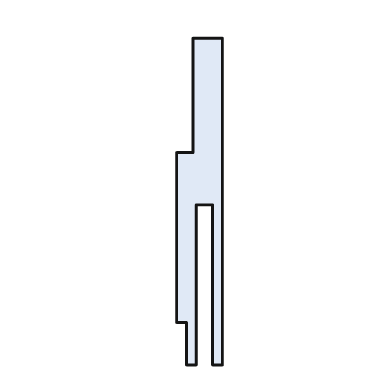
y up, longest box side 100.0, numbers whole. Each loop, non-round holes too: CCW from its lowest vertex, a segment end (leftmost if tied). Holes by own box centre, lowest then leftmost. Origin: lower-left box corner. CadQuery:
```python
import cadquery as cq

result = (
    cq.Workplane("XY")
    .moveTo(3.0, 0.0)
    .lineTo(6.0, 0.0)
    .lineTo(6.0, 49.0)
    .lineTo(11.0, 49.0)
    .lineTo(11.0, 0.0)
    .lineTo(14.0, 0.0)
    .lineTo(14.0, 100.0)
    .lineTo(5.0, 100.0)
    .lineTo(5.0, 65.0)
    .lineTo(0.0, 65.0)
    .lineTo(0.0, 13.0)
    .lineTo(3.0, 13.0)
    .close()
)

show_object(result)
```